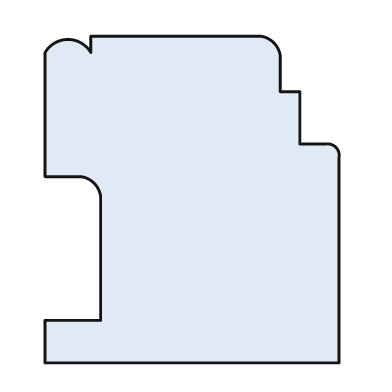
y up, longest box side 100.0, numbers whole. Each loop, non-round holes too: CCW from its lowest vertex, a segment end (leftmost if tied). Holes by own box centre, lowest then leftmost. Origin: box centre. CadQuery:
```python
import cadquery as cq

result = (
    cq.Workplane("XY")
    .moveTo(-45.0, -50.0)
    .lineTo(45.0, -50.0)
    .lineTo(45.0, 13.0)
    .threePointArc((44.0, 16.0), (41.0, 17.0))
    .lineTo(33.0, 17.0)
    .lineTo(33.0, 33.0)
    .lineTo(27.0, 33.0)
    .lineTo(27.0, 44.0)
    .threePointArc((25.0, 48.0), (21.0, 50.0))
    .lineTo(-31.0, 50.0)
    .lineTo(-31.0, 45.0)
    .threePointArc((-38.0, 49.0), (-45.0, 45.0))
    .lineTo(-45.0, 7.0)
    .lineTo(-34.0, 7.0)
    .threePointArc((-30.0, 5.0), (-28.0, 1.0))
    .lineTo(-28.0, -37.0)
    .lineTo(-45.0, -37.0)
    .close()
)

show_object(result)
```